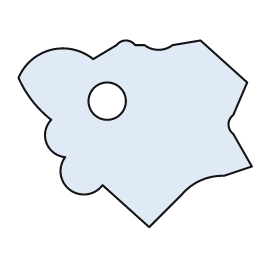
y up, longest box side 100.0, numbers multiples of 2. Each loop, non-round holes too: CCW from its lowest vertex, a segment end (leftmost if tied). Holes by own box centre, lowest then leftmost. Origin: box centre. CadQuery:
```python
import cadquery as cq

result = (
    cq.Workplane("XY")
    .moveTo(6.0, -40.0)
    .lineTo(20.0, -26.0)
    .threePointArc((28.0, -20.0), (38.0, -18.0))
    .lineTo(50.0, -14.0)
    .lineTo(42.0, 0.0)
    .threePointArc((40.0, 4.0), (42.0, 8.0))
    .lineTo(48.0, 22.0)
    .lineTo(28.0, 40.0)
    .lineTo(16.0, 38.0)
    .threePointArc((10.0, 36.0), (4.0, 38.0))
    .lineTo(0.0, 38.0)
    .threePointArc((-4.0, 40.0), (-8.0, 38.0))
    .lineTo(-18.0, 32.0)
    .threePointArc((-36.0, 36.0), (-50.0, 24.0))
    .threePointArc((-44.0, 14.0), (-36.0, 6.0))
    .threePointArc((-38.0, -4.0), (-30.0, -10.0))
    .threePointArc((-28.0, -24.0), (-14.0, -22.0))
    .close()
    .moveTo(-12.0, 14.0)
    .circle(8.0)
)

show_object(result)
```